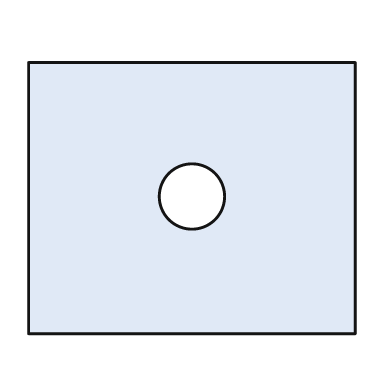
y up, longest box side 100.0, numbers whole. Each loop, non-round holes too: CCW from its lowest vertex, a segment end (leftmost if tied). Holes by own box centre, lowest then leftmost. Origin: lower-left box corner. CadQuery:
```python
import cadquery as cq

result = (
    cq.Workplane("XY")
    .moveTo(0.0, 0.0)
    .lineTo(100.0, 0.0)
    .lineTo(100.0, 83.0)
    .lineTo(0.0, 83.0)
    .close()
    .moveTo(50.0, 42.0)
    .circle(10.0)
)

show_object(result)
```